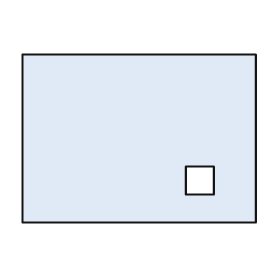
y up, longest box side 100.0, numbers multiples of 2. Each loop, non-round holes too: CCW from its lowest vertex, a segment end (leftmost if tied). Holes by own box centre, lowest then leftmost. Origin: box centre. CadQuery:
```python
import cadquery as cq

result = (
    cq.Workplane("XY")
    .moveTo(-50.0, -36.0)
    .lineTo(50.0, -36.0)
    .lineTo(50.0, 36.0)
    .lineTo(-50.0, 36.0)
    .close()
    .moveTo(20.0, -24.0)
    .lineTo(32.0, -24.0)
    .lineTo(32.0, -12.0)
    .lineTo(20.0, -12.0)
    .close()
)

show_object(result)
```